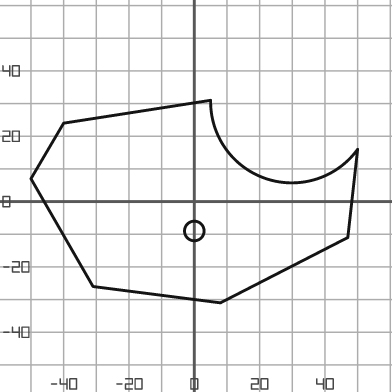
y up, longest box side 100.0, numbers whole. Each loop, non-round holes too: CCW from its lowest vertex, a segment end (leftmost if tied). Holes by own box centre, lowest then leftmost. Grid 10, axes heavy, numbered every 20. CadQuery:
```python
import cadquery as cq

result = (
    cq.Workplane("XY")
    .moveTo(8.0, -31.0)
    .lineTo(47.0, -11.0)
    .lineTo(50.0, 16.0)
    .threePointArc((22.0, 7.0), (5.0, 31.0))
    .lineTo(-40.0, 24.0)
    .lineTo(-50.0, 7.0)
    .lineTo(-31.0, -26.0)
    .close()
    .moveTo(0.0, -9.0)
    .circle(3.0)
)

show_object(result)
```